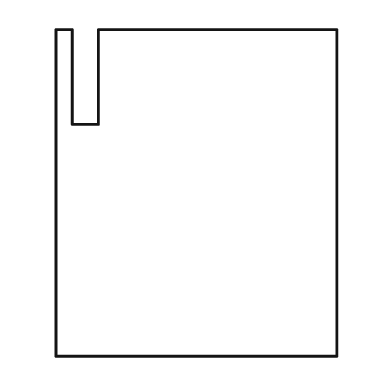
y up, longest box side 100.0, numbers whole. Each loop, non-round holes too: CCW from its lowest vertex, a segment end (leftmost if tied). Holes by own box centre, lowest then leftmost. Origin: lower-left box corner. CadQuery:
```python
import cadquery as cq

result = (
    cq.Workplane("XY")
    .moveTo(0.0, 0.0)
    .lineTo(86.0, 0.0)
    .lineTo(86.0, 100.0)
    .lineTo(13.0, 100.0)
    .lineTo(13.0, 71.0)
    .lineTo(5.0, 71.0)
    .lineTo(5.0, 100.0)
    .lineTo(0.0, 100.0)
    .close()
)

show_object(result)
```